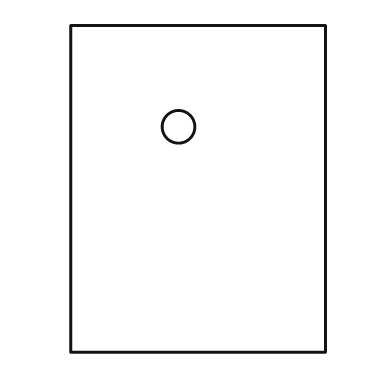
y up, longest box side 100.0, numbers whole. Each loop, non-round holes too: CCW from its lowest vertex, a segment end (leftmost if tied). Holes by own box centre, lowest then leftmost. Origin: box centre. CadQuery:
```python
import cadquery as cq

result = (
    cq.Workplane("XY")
    .moveTo(-39.0, -50.0)
    .lineTo(39.0, -50.0)
    .lineTo(39.0, 50.0)
    .lineTo(-39.0, 50.0)
    .close()
    .moveTo(-6.0, 19.0)
    .circle(5.0)
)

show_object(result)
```